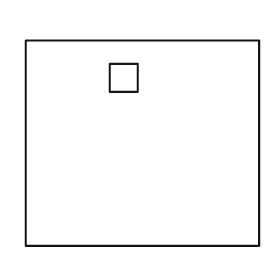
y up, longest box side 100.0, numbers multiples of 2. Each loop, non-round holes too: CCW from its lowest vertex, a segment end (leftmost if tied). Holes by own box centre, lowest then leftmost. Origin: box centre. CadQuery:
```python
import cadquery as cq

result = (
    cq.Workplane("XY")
    .moveTo(-50.0, -44.0)
    .lineTo(50.0, -44.0)
    .lineTo(50.0, 44.0)
    .lineTo(-50.0, 44.0)
    .close()
    .moveTo(-14.0, 22.0)
    .lineTo(-2.0, 22.0)
    .lineTo(-2.0, 34.0)
    .lineTo(-14.0, 34.0)
    .close()
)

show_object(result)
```